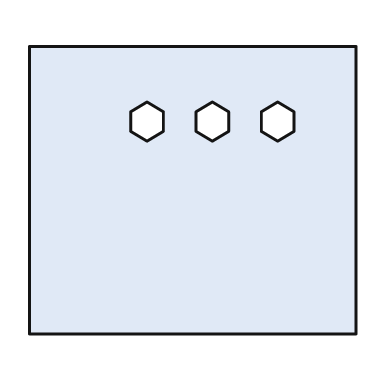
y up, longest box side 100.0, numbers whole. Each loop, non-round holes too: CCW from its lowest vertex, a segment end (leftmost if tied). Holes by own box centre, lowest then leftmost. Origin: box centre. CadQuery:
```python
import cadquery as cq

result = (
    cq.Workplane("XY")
    .moveTo(-50.0, -44.0)
    .lineTo(50.0, -44.0)
    .lineTo(50.0, 44.0)
    .lineTo(-50.0, 44.0)
    .close()
    .moveTo(-14.0, 15.0)
    .lineTo(-9.0, 18.0)
    .lineTo(-9.0, 24.0)
    .lineTo(-14.0, 27.0)
    .lineTo(-19.0, 24.0)
    .lineTo(-19.0, 18.0)
    .close()
    .moveTo(6.0, 15.0)
    .lineTo(11.0, 18.0)
    .lineTo(11.0, 24.0)
    .lineTo(6.0, 27.0)
    .lineTo(1.0, 24.0)
    .lineTo(1.0, 18.0)
    .close()
    .moveTo(26.0, 15.0)
    .lineTo(31.0, 18.0)
    .lineTo(31.0, 24.0)
    .lineTo(26.0, 27.0)
    .lineTo(21.0, 24.0)
    .lineTo(21.0, 18.0)
    .close()
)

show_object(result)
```